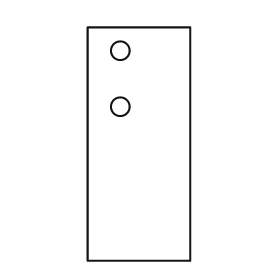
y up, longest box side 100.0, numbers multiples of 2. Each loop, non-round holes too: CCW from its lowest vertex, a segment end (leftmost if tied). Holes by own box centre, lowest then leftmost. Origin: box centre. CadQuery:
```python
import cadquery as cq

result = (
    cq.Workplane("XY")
    .moveTo(-22.0, -50.0)
    .lineTo(22.0, -50.0)
    .lineTo(22.0, 50.0)
    .lineTo(-22.0, 50.0)
    .close()
    .moveTo(-8.0, 16.0)
    .circle(4.0)
    .moveTo(-8.0, 40.0)
    .circle(4.0)
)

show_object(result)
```